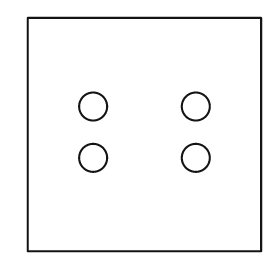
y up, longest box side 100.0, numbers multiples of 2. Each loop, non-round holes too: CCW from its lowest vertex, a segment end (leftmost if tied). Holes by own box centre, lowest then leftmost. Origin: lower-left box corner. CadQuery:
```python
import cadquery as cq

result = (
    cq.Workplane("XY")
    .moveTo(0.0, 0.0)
    .lineTo(100.0, 0.0)
    .lineTo(100.0, 100.0)
    .lineTo(0.0, 100.0)
    .close()
    .moveTo(28.0, 40.0)
    .circle(6.0)
    .moveTo(72.0, 40.0)
    .circle(6.0)
    .moveTo(28.0, 62.0)
    .circle(6.0)
    .moveTo(72.0, 62.0)
    .circle(6.0)
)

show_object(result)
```